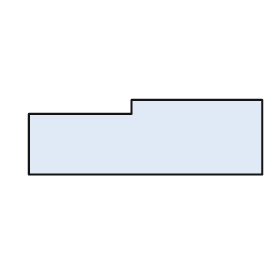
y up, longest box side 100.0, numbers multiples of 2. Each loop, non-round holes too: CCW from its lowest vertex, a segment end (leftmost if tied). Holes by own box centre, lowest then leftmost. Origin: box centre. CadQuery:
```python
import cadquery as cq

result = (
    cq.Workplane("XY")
    .moveTo(-50.0, -16.0)
    .lineTo(50.0, -16.0)
    .lineTo(50.0, 16.0)
    .lineTo(-6.0, 16.0)
    .lineTo(-6.0, 10.0)
    .lineTo(-50.0, 10.0)
    .close()
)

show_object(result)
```